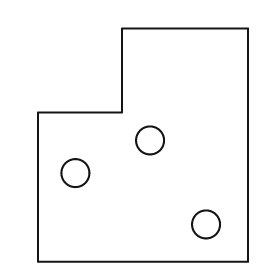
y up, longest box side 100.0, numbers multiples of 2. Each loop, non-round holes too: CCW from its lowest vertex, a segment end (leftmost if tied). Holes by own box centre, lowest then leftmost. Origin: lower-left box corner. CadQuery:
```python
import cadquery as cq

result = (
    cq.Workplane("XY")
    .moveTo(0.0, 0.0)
    .lineTo(90.0, 0.0)
    .lineTo(90.0, 100.0)
    .lineTo(36.0, 100.0)
    .lineTo(36.0, 64.0)
    .lineTo(0.0, 64.0)
    .close()
    .moveTo(72.0, 16.0)
    .circle(6.0)
    .moveTo(16.0, 38.0)
    .circle(6.0)
    .moveTo(48.0, 52.0)
    .circle(6.0)
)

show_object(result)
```